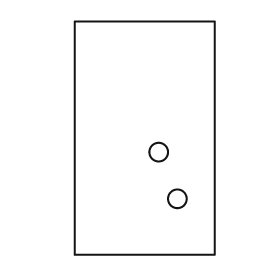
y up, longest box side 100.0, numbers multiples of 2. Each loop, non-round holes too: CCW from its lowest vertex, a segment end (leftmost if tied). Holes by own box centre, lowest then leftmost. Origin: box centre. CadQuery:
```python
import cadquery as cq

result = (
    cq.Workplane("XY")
    .moveTo(-30.0, -50.0)
    .lineTo(30.0, -50.0)
    .lineTo(30.0, 50.0)
    .lineTo(-30.0, 50.0)
    .close()
    .moveTo(14.0, -26.0)
    .circle(4.0)
    .moveTo(6.0, -6.0)
    .circle(4.0)
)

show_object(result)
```